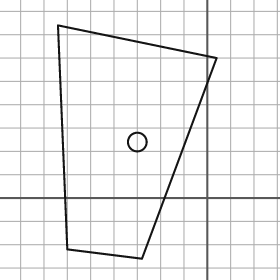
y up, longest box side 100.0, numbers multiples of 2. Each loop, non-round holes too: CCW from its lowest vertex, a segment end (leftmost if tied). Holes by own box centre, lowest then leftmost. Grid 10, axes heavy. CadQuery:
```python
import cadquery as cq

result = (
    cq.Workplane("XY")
    .moveTo(-28.0, -26.0)
    .lineTo(4.0, 60.0)
    .lineTo(-64.0, 74.0)
    .lineTo(-60.0, -22.0)
    .close()
    .moveTo(-30.0, 24.0)
    .circle(4.0)
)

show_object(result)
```